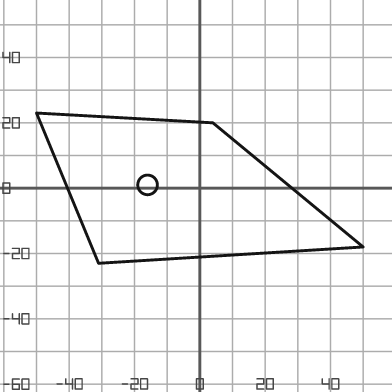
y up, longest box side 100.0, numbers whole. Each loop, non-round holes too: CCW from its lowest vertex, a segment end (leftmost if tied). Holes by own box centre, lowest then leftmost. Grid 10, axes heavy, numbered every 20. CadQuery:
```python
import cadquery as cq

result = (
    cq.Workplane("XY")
    .moveTo(-31.0, -23.0)
    .lineTo(50.0, -18.0)
    .lineTo(4.0, 20.0)
    .lineTo(-50.0, 23.0)
    .close()
    .moveTo(-16.0, 1.0)
    .circle(3.0)
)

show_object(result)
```